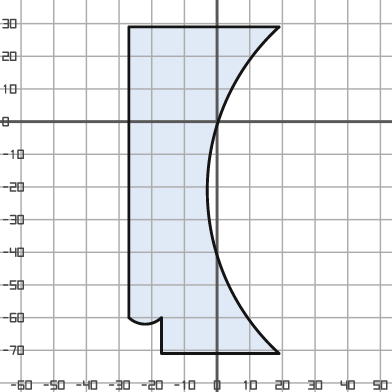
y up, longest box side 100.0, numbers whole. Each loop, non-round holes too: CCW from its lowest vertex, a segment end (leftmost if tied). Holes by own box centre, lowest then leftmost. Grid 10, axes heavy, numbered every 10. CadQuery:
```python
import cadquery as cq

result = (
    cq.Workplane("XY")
    .moveTo(-17.0, -71.0)
    .lineTo(19.0, -71.0)
    .threePointArc((-3.0, -21.0), (19.0, 29.0))
    .lineTo(-27.0, 29.0)
    .lineTo(-27.0, -60.0)
    .threePointArc((-22.0, -62.0), (-17.0, -60.0))
    .close()
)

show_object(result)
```